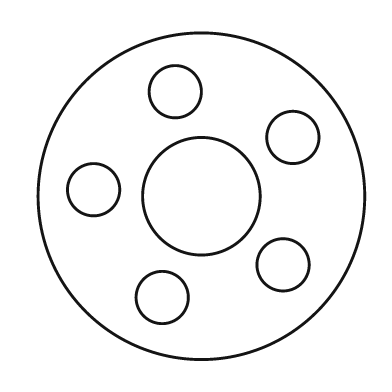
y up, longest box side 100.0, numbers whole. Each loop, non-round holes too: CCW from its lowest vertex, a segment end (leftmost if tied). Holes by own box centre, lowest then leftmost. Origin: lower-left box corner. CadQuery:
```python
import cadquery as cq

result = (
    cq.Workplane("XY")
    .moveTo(50.0, 50.0)
    .circle(50.0)
    .moveTo(38.0, 19.0)
    .circle(8.0)
    .moveTo(75.0, 29.0)
    .circle(8.0)
    .moveTo(50.0, 50.0)
    .circle(18.0)
    .moveTo(17.0, 52.0)
    .circle(8.0)
    .moveTo(78.0, 68.0)
    .circle(8.0)
    .moveTo(42.0, 82.0)
    .circle(8.0)
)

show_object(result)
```